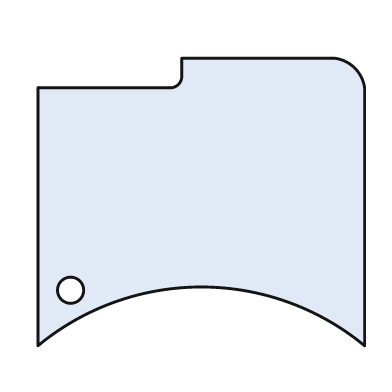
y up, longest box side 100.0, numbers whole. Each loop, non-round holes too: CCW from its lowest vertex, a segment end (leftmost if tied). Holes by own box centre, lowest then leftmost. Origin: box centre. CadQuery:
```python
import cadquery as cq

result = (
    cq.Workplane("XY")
    .moveTo(-50.0, -44.0)
    .threePointArc((0.0, -26.0), (50.0, -44.0))
    .lineTo(50.0, 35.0)
    .threePointArc((47.0, 41.0), (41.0, 44.0))
    .lineTo(-6.0, 44.0)
    .lineTo(-6.0, 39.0)
    .threePointArc((-7.0, 36.0), (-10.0, 35.0))
    .lineTo(-50.0, 35.0)
    .close()
    .moveTo(-40.0, -27.0)
    .circle(4.0)
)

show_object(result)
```